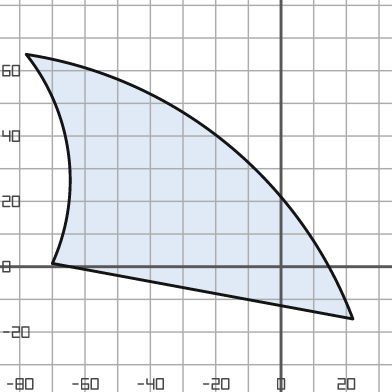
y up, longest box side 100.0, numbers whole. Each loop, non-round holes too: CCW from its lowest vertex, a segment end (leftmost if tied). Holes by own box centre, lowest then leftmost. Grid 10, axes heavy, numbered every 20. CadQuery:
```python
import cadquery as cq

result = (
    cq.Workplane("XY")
    .moveTo(22.0, -16.0)
    .threePointArc((-17.0, 38.0), (-78.0, 65.0))
    .threePointArc((-65.0, 34.0), (-70.0, 1.0))
    .close()
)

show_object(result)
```